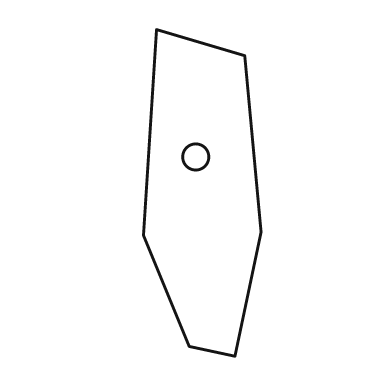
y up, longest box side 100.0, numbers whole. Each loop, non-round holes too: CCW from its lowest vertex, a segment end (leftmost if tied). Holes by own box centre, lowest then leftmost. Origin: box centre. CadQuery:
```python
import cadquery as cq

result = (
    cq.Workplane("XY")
    .moveTo(10.0, -50.0)
    .lineTo(18.0, -12.0)
    .lineTo(13.0, 42.0)
    .lineTo(-14.0, 50.0)
    .lineTo(-18.0, -13.0)
    .lineTo(-4.0, -47.0)
    .close()
    .moveTo(-2.0, 11.0)
    .circle(4.0)
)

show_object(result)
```